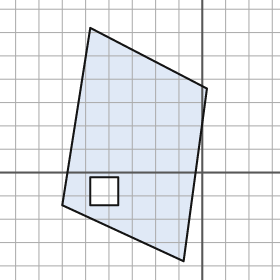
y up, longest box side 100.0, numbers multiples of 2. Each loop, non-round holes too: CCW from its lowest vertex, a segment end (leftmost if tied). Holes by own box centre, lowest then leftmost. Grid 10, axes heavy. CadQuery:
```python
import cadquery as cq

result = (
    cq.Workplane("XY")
    .moveTo(-8.0, -38.0)
    .lineTo(2.0, 36.0)
    .lineTo(-48.0, 62.0)
    .lineTo(-60.0, -14.0)
    .close()
    .moveTo(-48.0, -14.0)
    .lineTo(-36.0, -14.0)
    .lineTo(-36.0, -2.0)
    .lineTo(-48.0, -2.0)
    .close()
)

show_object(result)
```